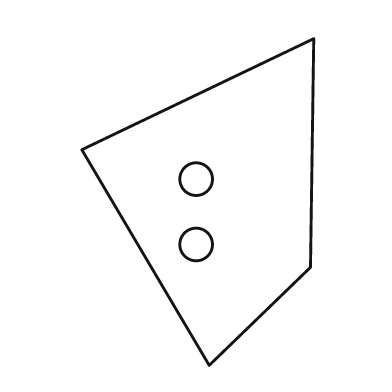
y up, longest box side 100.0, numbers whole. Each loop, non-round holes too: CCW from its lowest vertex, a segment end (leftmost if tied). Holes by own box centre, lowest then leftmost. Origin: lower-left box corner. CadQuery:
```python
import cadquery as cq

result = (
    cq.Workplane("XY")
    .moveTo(39.0, 0.0)
    .lineTo(70.0, 30.0)
    .lineTo(71.0, 100.0)
    .lineTo(0.0, 66.0)
    .close()
    .moveTo(35.0, 37.0)
    .circle(5.0)
    .moveTo(35.0, 57.0)
    .circle(5.0)
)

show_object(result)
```